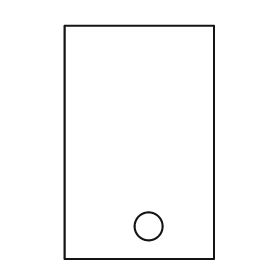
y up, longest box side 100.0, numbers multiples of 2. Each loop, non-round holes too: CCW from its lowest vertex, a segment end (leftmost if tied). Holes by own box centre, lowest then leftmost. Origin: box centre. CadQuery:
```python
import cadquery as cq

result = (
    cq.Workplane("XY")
    .moveTo(-32.0, -50.0)
    .lineTo(32.0, -50.0)
    .lineTo(32.0, 50.0)
    .lineTo(-32.0, 50.0)
    .close()
    .moveTo(4.0, -36.0)
    .circle(6.0)
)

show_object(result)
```